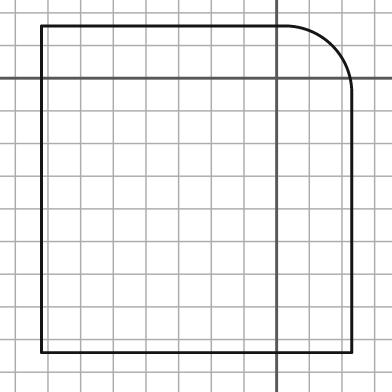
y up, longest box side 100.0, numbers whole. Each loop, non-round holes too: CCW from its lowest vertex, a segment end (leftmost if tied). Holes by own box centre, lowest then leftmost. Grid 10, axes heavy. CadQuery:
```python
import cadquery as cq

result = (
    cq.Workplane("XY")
    .moveTo(-72.0, -84.0)
    .lineTo(23.0, -84.0)
    .lineTo(23.0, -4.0)
    .threePointArc((17.0, 10.0), (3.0, 16.0))
    .lineTo(-72.0, 16.0)
    .close()
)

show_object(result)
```